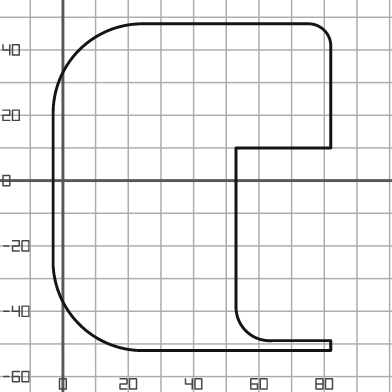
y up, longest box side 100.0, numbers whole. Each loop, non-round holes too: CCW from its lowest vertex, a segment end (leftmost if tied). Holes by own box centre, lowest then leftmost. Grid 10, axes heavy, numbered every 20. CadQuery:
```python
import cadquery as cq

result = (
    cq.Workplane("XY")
    .moveTo(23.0, -52.0)
    .lineTo(82.0, -52.0)
    .lineTo(82.0, -49.0)
    .lineTo(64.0, -49.0)
    .threePointArc((56.0, -46.0), (53.0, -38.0))
    .lineTo(53.0, 10.0)
    .lineTo(82.0, 10.0)
    .lineTo(82.0, 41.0)
    .threePointArc((80.0, 46.0), (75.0, 48.0))
    .lineTo(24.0, 48.0)
    .threePointArc((5.0, 40.0), (-3.0, 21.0))
    .lineTo(-3.0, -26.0)
    .threePointArc((5.0, -44.0), (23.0, -52.0))
    .close()
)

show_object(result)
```